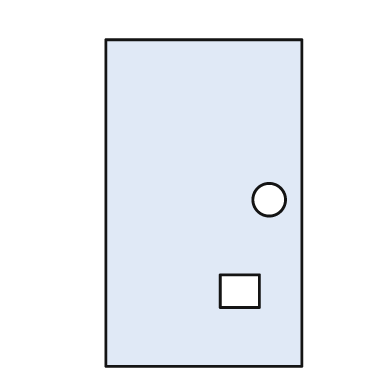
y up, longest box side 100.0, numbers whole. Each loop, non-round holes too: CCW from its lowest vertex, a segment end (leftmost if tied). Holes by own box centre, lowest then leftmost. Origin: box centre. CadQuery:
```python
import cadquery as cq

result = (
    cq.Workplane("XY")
    .moveTo(-30.0, -50.0)
    .lineTo(30.0, -50.0)
    .lineTo(30.0, 50.0)
    .lineTo(-30.0, 50.0)
    .close()
    .moveTo(5.0, -32.0)
    .lineTo(17.0, -32.0)
    .lineTo(17.0, -22.0)
    .lineTo(5.0, -22.0)
    .close()
    .moveTo(20.0, 1.0)
    .circle(5.0)
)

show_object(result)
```